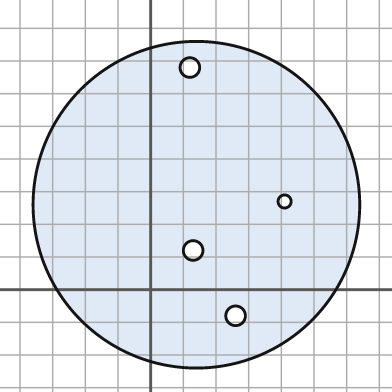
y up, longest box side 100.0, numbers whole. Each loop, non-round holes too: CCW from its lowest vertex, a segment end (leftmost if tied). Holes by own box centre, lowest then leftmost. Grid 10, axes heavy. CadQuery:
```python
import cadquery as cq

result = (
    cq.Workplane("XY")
    .moveTo(14.0, 26.0)
    .circle(50.0)
    .moveTo(26.0, -8.0)
    .circle(3.0)
    .moveTo(13.0, 12.0)
    .circle(3.0)
    .moveTo(41.0, 27.0)
    .circle(2.0)
    .moveTo(12.0, 68.0)
    .circle(3.0)
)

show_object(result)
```